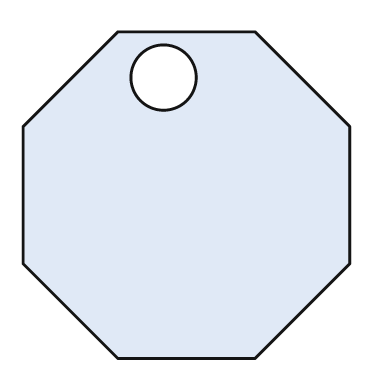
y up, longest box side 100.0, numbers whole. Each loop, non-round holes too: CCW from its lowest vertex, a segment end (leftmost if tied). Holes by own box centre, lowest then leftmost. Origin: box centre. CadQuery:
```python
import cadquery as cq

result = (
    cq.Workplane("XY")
    .moveTo(-21.0, -50.0)
    .lineTo(21.0, -50.0)
    .lineTo(50.0, -21.0)
    .lineTo(50.0, 21.0)
    .lineTo(21.0, 50.0)
    .lineTo(-21.0, 50.0)
    .lineTo(-50.0, 21.0)
    .lineTo(-50.0, -21.0)
    .close()
    .moveTo(-7.0, 36.0)
    .circle(10.0)
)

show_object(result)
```